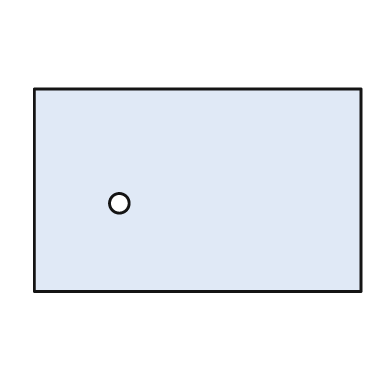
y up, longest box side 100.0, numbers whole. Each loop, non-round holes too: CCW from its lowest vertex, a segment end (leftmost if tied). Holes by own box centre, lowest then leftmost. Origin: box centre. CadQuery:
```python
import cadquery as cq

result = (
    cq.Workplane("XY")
    .moveTo(-50.0, -31.0)
    .lineTo(50.0, -31.0)
    .lineTo(50.0, 31.0)
    .lineTo(-50.0, 31.0)
    .close()
    .moveTo(-24.0, -4.0)
    .circle(3.0)
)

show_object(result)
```